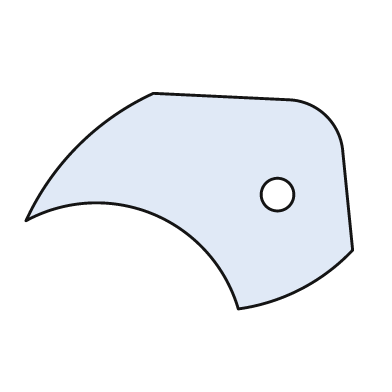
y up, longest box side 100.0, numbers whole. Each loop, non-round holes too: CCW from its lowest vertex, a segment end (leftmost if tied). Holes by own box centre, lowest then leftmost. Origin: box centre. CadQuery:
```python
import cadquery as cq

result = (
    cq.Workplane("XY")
    .moveTo(15.0, -33.0)
    .threePointArc((34.0, -27.0), (50.0, -15.0))
    .lineTo(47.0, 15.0)
    .threePointArc((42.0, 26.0), (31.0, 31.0))
    .lineTo(-11.0, 33.0)
    .threePointArc((-34.0, 17.0), (-50.0, -6.0))
    .threePointArc((-11.0, -4.0), (15.0, -33.0))
    .close()
    .moveTo(27.0, 2.0)
    .circle(5.0)
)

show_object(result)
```